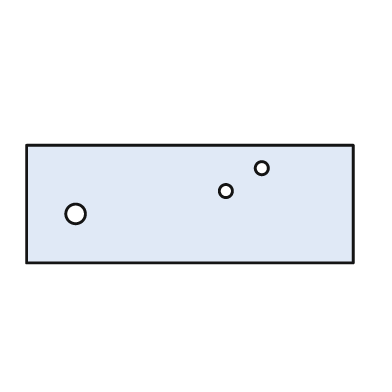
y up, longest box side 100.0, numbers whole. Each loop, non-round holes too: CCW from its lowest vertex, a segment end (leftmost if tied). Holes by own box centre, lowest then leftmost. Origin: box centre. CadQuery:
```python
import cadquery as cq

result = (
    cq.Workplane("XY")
    .moveTo(-50.0, -18.0)
    .lineTo(50.0, -18.0)
    .lineTo(50.0, 18.0)
    .lineTo(-50.0, 18.0)
    .close()
    .moveTo(-35.0, -3.0)
    .circle(3.0)
    .moveTo(11.0, 4.0)
    .circle(2.0)
    .moveTo(22.0, 11.0)
    .circle(2.0)
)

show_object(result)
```